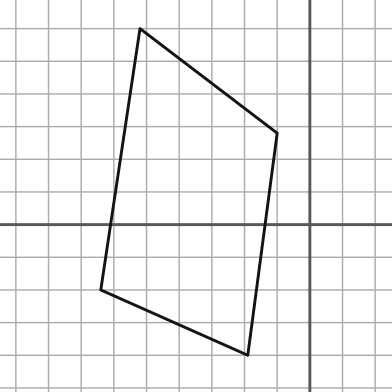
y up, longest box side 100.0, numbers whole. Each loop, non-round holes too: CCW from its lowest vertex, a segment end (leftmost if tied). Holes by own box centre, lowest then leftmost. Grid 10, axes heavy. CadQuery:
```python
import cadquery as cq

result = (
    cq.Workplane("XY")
    .moveTo(-19.0, -40.0)
    .lineTo(-10.0, 28.0)
    .lineTo(-52.0, 60.0)
    .lineTo(-64.0, -20.0)
    .close()
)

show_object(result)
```